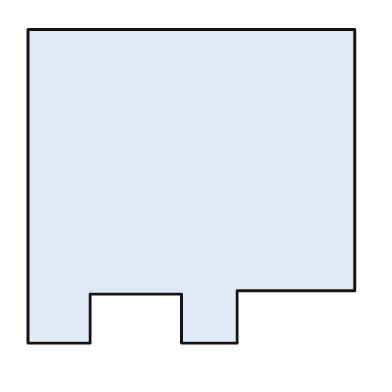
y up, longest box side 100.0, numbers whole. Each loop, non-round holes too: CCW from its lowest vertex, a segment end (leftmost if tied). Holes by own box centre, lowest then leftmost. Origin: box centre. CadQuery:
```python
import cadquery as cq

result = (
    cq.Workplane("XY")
    .moveTo(-50.0, -48.0)
    .lineTo(-31.0, -48.0)
    .lineTo(-31.0, -33.0)
    .lineTo(-3.0, -33.0)
    .lineTo(-3.0, -48.0)
    .lineTo(14.0, -48.0)
    .lineTo(14.0, -32.0)
    .lineTo(50.0, -32.0)
    .lineTo(50.0, 48.0)
    .lineTo(-50.0, 48.0)
    .close()
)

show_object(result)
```